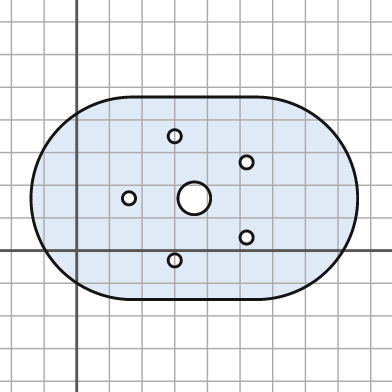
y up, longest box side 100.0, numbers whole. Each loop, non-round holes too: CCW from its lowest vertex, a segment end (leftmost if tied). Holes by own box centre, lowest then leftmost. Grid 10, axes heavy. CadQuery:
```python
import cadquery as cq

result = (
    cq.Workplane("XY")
    .moveTo(17.0, -15.0)
    .lineTo(55.0, -15.0)
    .threePointArc((86.0, 16.0), (55.0, 47.0))
    .lineTo(17.0, 47.0)
    .threePointArc((-14.0, 16.0), (17.0, -15.0))
    .close()
    .moveTo(30.0, -3.0)
    .circle(2.0)
    .moveTo(52.0, 4.0)
    .circle(2.0)
    .moveTo(16.0, 16.0)
    .circle(2.0)
    .moveTo(36.0, 16.0)
    .circle(5.0)
    .moveTo(52.0, 27.0)
    .circle(2.0)
    .moveTo(30.0, 35.0)
    .circle(2.0)
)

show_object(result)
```